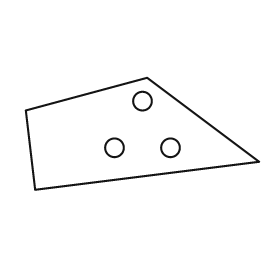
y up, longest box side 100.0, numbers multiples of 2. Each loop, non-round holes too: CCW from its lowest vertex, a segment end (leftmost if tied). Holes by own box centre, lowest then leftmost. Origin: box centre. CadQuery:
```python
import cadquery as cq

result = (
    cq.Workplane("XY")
    .moveTo(-46.0, -24.0)
    .lineTo(50.0, -12.0)
    .lineTo(2.0, 24.0)
    .lineTo(-50.0, 10.0)
    .close()
    .moveTo(-12.0, -6.0)
    .circle(4.0)
    .moveTo(12.0, -6.0)
    .circle(4.0)
    .moveTo(0.0, 14.0)
    .circle(4.0)
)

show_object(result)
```